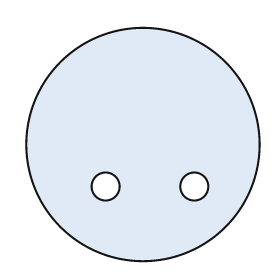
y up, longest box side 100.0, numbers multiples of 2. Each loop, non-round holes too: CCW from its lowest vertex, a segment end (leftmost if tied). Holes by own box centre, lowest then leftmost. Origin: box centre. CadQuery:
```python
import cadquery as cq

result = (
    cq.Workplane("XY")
    .moveTo(0.0, 0.0)
    .circle(50.0)
    .moveTo(-16.0, -18.0)
    .circle(6.0)
    .moveTo(22.0, -18.0)
    .circle(6.0)
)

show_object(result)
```